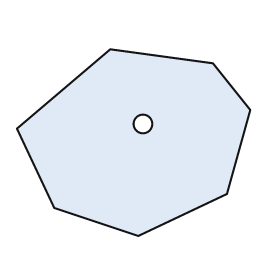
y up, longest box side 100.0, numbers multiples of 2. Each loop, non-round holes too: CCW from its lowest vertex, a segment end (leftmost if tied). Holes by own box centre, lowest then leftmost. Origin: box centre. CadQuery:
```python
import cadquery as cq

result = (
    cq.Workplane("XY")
    .moveTo(2.0, -40.0)
    .lineTo(40.0, -22.0)
    .lineTo(50.0, 14.0)
    .lineTo(34.0, 34.0)
    .lineTo(-10.0, 40.0)
    .lineTo(-50.0, 6.0)
    .lineTo(-34.0, -28.0)
    .close()
    .moveTo(4.0, 8.0)
    .circle(4.0)
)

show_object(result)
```